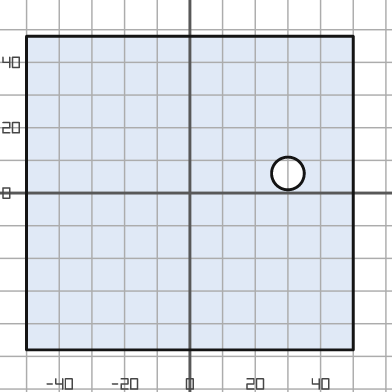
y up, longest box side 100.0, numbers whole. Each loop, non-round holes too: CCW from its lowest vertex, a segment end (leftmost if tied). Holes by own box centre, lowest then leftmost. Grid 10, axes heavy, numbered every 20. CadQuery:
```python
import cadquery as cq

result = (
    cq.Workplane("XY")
    .moveTo(-50.0, -48.0)
    .lineTo(50.0, -48.0)
    .lineTo(50.0, 48.0)
    .lineTo(-50.0, 48.0)
    .close()
    .moveTo(30.0, 6.0)
    .circle(5.0)
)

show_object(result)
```